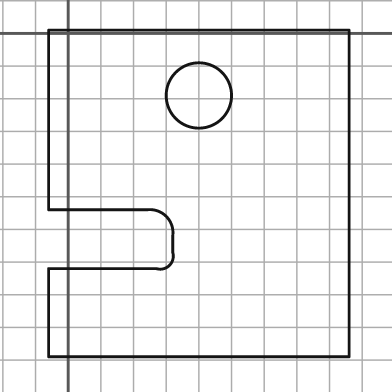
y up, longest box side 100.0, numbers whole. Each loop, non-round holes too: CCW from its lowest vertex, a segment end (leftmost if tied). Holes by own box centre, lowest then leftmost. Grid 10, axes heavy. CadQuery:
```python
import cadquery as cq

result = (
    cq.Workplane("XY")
    .moveTo(-6.0, -99.0)
    .lineTo(86.0, -99.0)
    .lineTo(86.0, 1.0)
    .lineTo(-6.0, 1.0)
    .lineTo(-6.0, -54.0)
    .lineTo(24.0, -54.0)
    .threePointArc((30.0, -56.0), (32.0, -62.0))
    .lineTo(32.0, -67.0)
    .threePointArc((31.0, -71.0), (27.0, -72.0))
    .lineTo(-6.0, -72.0)
    .close()
    .moveTo(40.0, -19.0)
    .circle(10.0)
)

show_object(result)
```